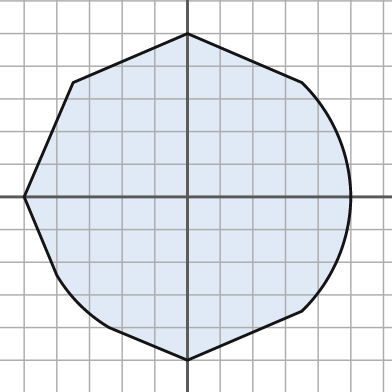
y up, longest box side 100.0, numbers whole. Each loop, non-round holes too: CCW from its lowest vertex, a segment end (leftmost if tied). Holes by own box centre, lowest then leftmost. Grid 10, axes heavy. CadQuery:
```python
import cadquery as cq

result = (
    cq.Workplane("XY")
    .moveTo(0.0, -50.0)
    .lineTo(35.0, -35.0)
    .threePointArc((46.0, -19.0), (50.0, 0.0))
    .threePointArc((46.0, 19.0), (35.0, 35.0))
    .lineTo(0.0, 50.0)
    .lineTo(-35.0, 35.0)
    .lineTo(-50.0, 0.0)
    .lineTo(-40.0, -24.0)
    .threePointArc((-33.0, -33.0), (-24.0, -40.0))
    .close()
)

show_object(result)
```